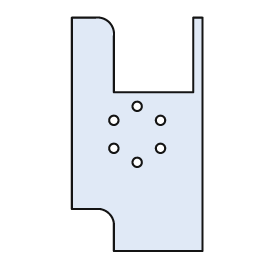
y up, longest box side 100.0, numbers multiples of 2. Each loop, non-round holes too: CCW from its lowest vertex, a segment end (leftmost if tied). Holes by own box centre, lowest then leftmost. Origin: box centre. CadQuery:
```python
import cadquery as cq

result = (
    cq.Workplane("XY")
    .moveTo(-10.0, -50.0)
    .lineTo(28.0, -50.0)
    .lineTo(28.0, 50.0)
    .lineTo(24.0, 50.0)
    .lineTo(24.0, 18.0)
    .lineTo(-10.0, 18.0)
    .lineTo(-10.0, 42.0)
    .threePointArc((-12.0, 48.0), (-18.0, 50.0))
    .lineTo(-28.0, 50.0)
    .lineTo(-28.0, -32.0)
    .lineTo(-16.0, -32.0)
    .threePointArc((-12.0, -34.0), (-10.0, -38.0))
    .close()
    .moveTo(0.0, -12.0)
    .circle(2.0)
    .moveTo(-10.0, -6.0)
    .circle(2.0)
    .moveTo(10.0, -6.0)
    .circle(2.0)
    .moveTo(-10.0, 6.0)
    .circle(2.0)
    .moveTo(10.0, 6.0)
    .circle(2.0)
    .moveTo(0.0, 12.0)
    .circle(2.0)
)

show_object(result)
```